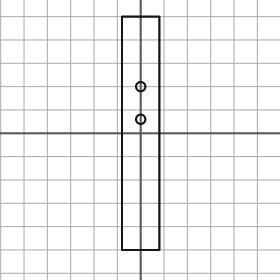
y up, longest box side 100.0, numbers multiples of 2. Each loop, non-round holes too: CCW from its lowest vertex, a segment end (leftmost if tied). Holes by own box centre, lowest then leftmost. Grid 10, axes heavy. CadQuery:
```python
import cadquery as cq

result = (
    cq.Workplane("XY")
    .moveTo(-8.0, -50.0)
    .lineTo(8.0, -50.0)
    .lineTo(8.0, 50.0)
    .lineTo(-8.0, 50.0)
    .close()
    .moveTo(0.0, 6.0)
    .circle(2.0)
    .moveTo(0.0, 20.0)
    .circle(2.0)
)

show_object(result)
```